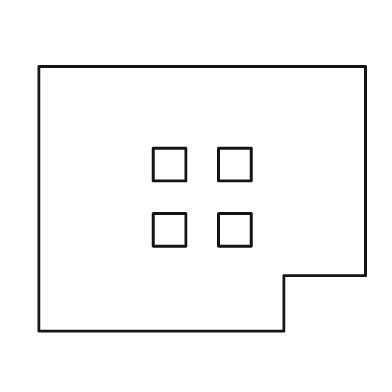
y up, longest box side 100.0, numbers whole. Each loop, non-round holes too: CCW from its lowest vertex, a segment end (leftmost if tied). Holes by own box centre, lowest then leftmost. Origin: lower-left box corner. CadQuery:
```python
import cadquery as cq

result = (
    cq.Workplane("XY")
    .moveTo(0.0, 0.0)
    .lineTo(75.0, 0.0)
    .lineTo(75.0, 17.0)
    .lineTo(100.0, 17.0)
    .lineTo(100.0, 81.0)
    .lineTo(0.0, 81.0)
    .close()
    .moveTo(35.0, 26.0)
    .lineTo(45.0, 26.0)
    .lineTo(45.0, 36.0)
    .lineTo(35.0, 36.0)
    .close()
    .moveTo(55.0, 26.0)
    .lineTo(65.0, 26.0)
    .lineTo(65.0, 36.0)
    .lineTo(55.0, 36.0)
    .close()
    .moveTo(35.0, 46.0)
    .lineTo(45.0, 46.0)
    .lineTo(45.0, 56.0)
    .lineTo(35.0, 56.0)
    .close()
    .moveTo(55.0, 46.0)
    .lineTo(65.0, 46.0)
    .lineTo(65.0, 56.0)
    .lineTo(55.0, 56.0)
    .close()
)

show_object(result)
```